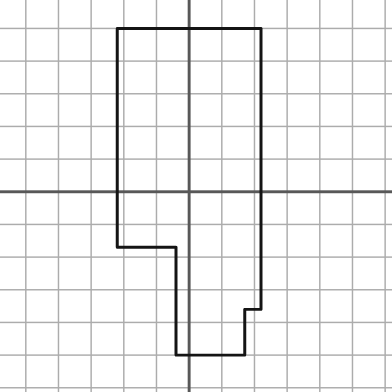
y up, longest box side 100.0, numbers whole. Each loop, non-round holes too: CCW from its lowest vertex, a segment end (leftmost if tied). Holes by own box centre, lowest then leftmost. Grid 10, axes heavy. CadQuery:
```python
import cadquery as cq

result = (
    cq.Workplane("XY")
    .moveTo(-4.0, -50.0)
    .lineTo(17.0, -50.0)
    .lineTo(17.0, -36.0)
    .lineTo(22.0, -36.0)
    .lineTo(22.0, 50.0)
    .lineTo(-22.0, 50.0)
    .lineTo(-22.0, -17.0)
    .lineTo(-4.0, -17.0)
    .close()
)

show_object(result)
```